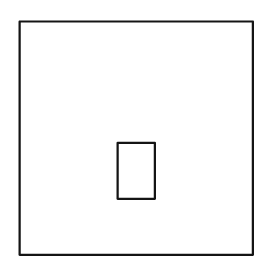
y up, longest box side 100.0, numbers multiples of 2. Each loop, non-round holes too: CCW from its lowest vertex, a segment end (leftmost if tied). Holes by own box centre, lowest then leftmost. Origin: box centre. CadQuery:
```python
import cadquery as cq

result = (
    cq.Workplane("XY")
    .moveTo(-50.0, -50.0)
    .lineTo(50.0, -50.0)
    .lineTo(50.0, 50.0)
    .lineTo(-50.0, 50.0)
    .close()
    .moveTo(-8.0, -26.0)
    .lineTo(8.0, -26.0)
    .lineTo(8.0, -2.0)
    .lineTo(-8.0, -2.0)
    .close()
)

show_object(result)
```